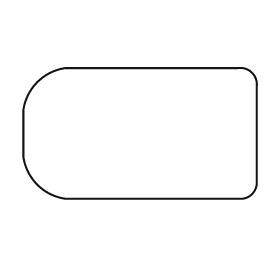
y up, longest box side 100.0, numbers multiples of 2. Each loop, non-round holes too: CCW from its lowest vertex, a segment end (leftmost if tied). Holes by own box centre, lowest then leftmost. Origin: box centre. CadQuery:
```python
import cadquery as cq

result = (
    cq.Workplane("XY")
    .moveTo(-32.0, -28.0)
    .lineTo(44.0, -28.0)
    .threePointArc((48.0, -26.0), (50.0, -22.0))
    .lineTo(50.0, 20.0)
    .threePointArc((48.0, 26.0), (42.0, 28.0))
    .lineTo(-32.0, 28.0)
    .threePointArc((-44.0, 22.0), (-50.0, 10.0))
    .lineTo(-50.0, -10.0)
    .threePointArc((-44.0, -22.0), (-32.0, -28.0))
    .close()
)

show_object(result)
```